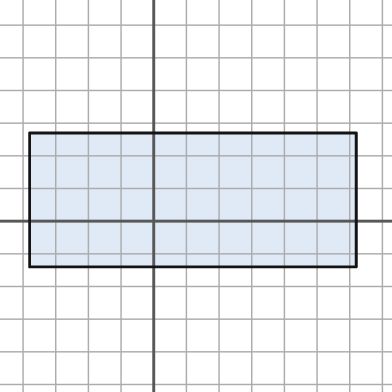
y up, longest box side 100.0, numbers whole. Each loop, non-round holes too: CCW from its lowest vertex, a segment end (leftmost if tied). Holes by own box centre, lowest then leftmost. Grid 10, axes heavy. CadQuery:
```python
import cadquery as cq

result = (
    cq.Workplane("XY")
    .moveTo(-38.0, -14.0)
    .lineTo(62.0, -14.0)
    .lineTo(62.0, 27.0)
    .lineTo(-38.0, 27.0)
    .close()
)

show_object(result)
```